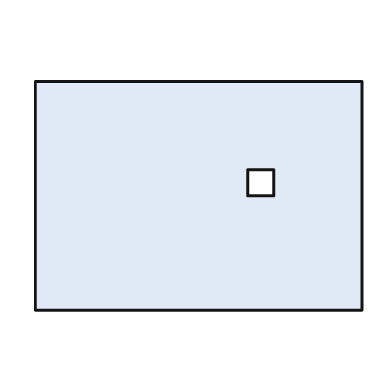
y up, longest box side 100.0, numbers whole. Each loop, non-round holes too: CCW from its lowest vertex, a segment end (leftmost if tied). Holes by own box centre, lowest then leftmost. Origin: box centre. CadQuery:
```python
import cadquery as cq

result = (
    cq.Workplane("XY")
    .moveTo(-50.0, -35.0)
    .lineTo(50.0, -35.0)
    .lineTo(50.0, 35.0)
    .lineTo(-50.0, 35.0)
    .close()
    .moveTo(15.0, 0.0)
    .lineTo(23.0, 0.0)
    .lineTo(23.0, 8.0)
    .lineTo(15.0, 8.0)
    .close()
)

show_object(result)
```